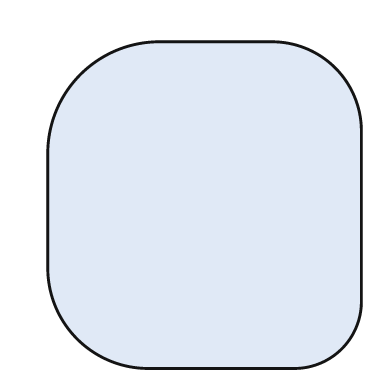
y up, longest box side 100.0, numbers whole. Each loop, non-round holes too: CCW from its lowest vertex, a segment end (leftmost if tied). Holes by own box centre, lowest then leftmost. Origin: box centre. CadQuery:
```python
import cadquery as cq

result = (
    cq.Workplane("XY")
    .moveTo(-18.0, -50.0)
    .lineTo(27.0, -50.0)
    .threePointArc((42.0, -44.0), (48.0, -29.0))
    .lineTo(48.0, 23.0)
    .threePointArc((40.0, 42.0), (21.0, 50.0))
    .lineTo(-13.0, 50.0)
    .threePointArc((-38.0, 40.0), (-48.0, 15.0))
    .lineTo(-48.0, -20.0)
    .threePointArc((-39.0, -41.0), (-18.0, -50.0))
    .close()
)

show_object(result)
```